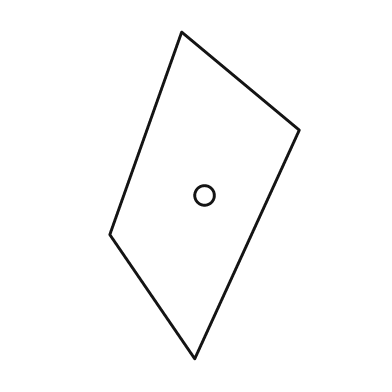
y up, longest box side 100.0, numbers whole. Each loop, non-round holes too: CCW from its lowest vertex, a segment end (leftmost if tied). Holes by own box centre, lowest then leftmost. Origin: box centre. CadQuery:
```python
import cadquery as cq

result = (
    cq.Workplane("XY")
    .moveTo(-3.0, -50.0)
    .lineTo(29.0, 20.0)
    .lineTo(-7.0, 50.0)
    .lineTo(-29.0, -12.0)
    .close()
    .moveTo(0.0, 0.0)
    .circle(3.0)
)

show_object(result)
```